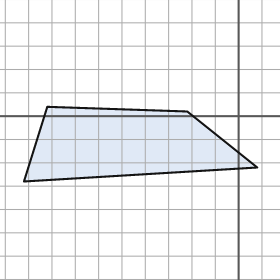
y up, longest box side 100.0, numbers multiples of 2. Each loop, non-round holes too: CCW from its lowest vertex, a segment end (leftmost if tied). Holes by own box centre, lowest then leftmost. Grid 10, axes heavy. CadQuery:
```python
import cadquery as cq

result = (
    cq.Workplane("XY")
    .moveTo(-92.0, -28.0)
    .lineTo(8.0, -22.0)
    .lineTo(-22.0, 2.0)
    .lineTo(-82.0, 4.0)
    .close()
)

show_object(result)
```